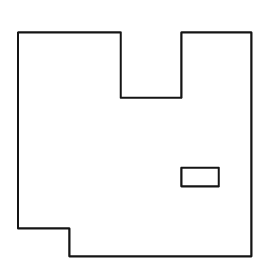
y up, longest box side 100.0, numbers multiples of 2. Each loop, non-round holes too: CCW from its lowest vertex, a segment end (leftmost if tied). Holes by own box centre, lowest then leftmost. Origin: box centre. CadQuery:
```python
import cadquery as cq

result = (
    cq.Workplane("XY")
    .moveTo(-28.0, -48.0)
    .lineTo(50.0, -48.0)
    .lineTo(50.0, 48.0)
    .lineTo(20.0, 48.0)
    .lineTo(20.0, 20.0)
    .lineTo(-6.0, 20.0)
    .lineTo(-6.0, 48.0)
    .lineTo(-50.0, 48.0)
    .lineTo(-50.0, -36.0)
    .lineTo(-28.0, -36.0)
    .close()
    .moveTo(20.0, -18.0)
    .lineTo(36.0, -18.0)
    .lineTo(36.0, -10.0)
    .lineTo(20.0, -10.0)
    .close()
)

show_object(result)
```